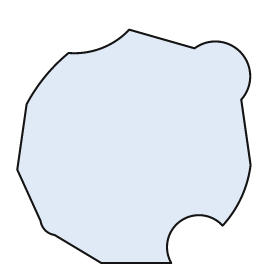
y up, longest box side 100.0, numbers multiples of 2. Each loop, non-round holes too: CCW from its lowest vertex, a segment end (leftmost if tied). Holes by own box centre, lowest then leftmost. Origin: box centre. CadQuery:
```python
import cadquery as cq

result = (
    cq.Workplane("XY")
    .moveTo(-14.0, -50.0)
    .lineTo(16.0, -50.0)
    .threePointArc((20.0, -32.0), (38.0, -34.0))
    .threePointArc((46.0, -22.0), (50.0, -8.0))
    .lineTo(46.0, 20.0)
    .threePointArc((46.0, 40.0), (26.0, 42.0))
    .lineTo(-2.0, 50.0)
    .threePointArc((-14.0, 42.0), (-28.0, 40.0))
    .threePointArc((-38.0, 30.0), (-46.0, 18.0))
    .lineTo(-50.0, -10.0)
    .lineTo(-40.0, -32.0)
    .threePointArc((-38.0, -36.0), (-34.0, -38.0))
    .close()
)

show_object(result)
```